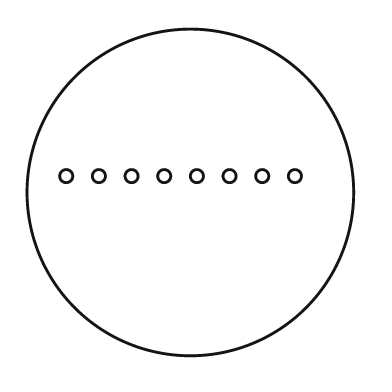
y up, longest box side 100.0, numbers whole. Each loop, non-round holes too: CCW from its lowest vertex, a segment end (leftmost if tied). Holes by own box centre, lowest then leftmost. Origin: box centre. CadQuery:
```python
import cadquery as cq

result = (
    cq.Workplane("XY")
    .moveTo(0.0, 0.0)
    .circle(50.0)
    .moveTo(-38.0, 5.0)
    .circle(2.0)
    .moveTo(-28.0, 5.0)
    .circle(2.0)
    .moveTo(-18.0, 5.0)
    .circle(2.0)
    .moveTo(-8.0, 5.0)
    .circle(2.0)
    .moveTo(2.0, 5.0)
    .circle(2.0)
    .moveTo(12.0, 5.0)
    .circle(2.0)
    .moveTo(22.0, 5.0)
    .circle(2.0)
    .moveTo(32.0, 5.0)
    .circle(2.0)
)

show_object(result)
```